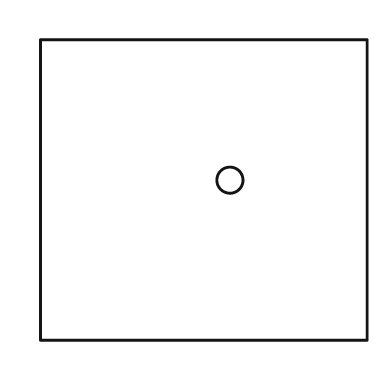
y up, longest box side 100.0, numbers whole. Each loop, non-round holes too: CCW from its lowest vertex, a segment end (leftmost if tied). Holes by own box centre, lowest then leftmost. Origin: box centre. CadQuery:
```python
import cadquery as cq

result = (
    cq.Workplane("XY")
    .moveTo(-50.0, -46.0)
    .lineTo(50.0, -46.0)
    .lineTo(50.0, 46.0)
    .lineTo(-50.0, 46.0)
    .close()
    .moveTo(8.0, 3.0)
    .circle(4.0)
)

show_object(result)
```